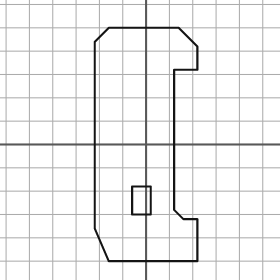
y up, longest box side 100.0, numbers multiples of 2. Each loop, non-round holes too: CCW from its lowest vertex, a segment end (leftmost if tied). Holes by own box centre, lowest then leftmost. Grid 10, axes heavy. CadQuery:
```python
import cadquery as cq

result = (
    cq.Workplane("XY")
    .moveTo(-16.0, -50.0)
    .lineTo(22.0, -50.0)
    .lineTo(22.0, -32.0)
    .lineTo(16.0, -32.0)
    .lineTo(12.0, -28.0)
    .lineTo(12.0, 32.0)
    .lineTo(22.0, 32.0)
    .lineTo(22.0, 42.0)
    .lineTo(14.0, 50.0)
    .lineTo(-16.0, 50.0)
    .lineTo(-22.0, 44.0)
    .lineTo(-22.0, -36.0)
    .close()
    .moveTo(-6.0, -30.0)
    .lineTo(2.0, -30.0)
    .lineTo(2.0, -18.0)
    .lineTo(-6.0, -18.0)
    .close()
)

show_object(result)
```